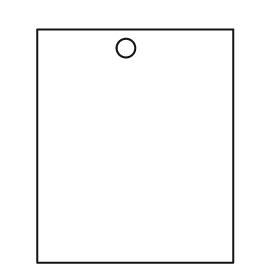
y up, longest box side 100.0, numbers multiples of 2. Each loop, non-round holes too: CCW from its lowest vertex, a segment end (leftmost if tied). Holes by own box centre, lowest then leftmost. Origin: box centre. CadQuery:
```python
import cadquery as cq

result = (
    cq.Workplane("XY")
    .moveTo(-42.0, -50.0)
    .lineTo(42.0, -50.0)
    .lineTo(42.0, 50.0)
    .lineTo(-42.0, 50.0)
    .close()
    .moveTo(-4.0, 42.0)
    .circle(4.0)
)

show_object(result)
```